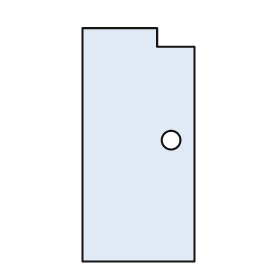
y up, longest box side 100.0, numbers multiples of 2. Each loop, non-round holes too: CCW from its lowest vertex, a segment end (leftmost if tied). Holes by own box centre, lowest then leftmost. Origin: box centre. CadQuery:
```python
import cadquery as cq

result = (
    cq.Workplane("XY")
    .moveTo(-24.0, -50.0)
    .lineTo(24.0, -50.0)
    .lineTo(24.0, 42.0)
    .lineTo(8.0, 42.0)
    .lineTo(8.0, 50.0)
    .lineTo(-24.0, 50.0)
    .close()
    .moveTo(14.0, 2.0)
    .circle(4.0)
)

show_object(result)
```